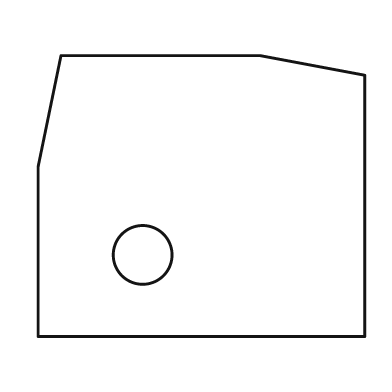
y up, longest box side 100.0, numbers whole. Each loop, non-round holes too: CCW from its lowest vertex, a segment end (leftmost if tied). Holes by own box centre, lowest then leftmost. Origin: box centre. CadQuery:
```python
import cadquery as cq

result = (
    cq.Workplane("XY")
    .moveTo(-50.0, -43.0)
    .lineTo(50.0, -43.0)
    .lineTo(50.0, 37.0)
    .lineTo(18.0, 43.0)
    .lineTo(-43.0, 43.0)
    .lineTo(-50.0, 9.0)
    .close()
    .moveTo(-18.0, -18.0)
    .circle(9.0)
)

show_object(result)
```